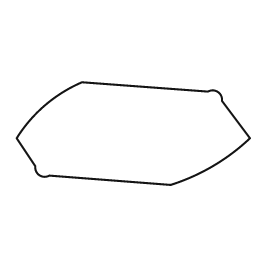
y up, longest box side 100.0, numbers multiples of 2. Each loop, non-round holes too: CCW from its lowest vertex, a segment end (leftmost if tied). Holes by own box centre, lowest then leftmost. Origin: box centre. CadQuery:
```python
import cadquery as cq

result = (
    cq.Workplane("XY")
    .moveTo(16.0, -22.0)
    .threePointArc((34.0, -14.0), (50.0, -2.0))
    .lineTo(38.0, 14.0)
    .threePointArc((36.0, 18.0), (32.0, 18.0))
    .lineTo(-22.0, 22.0)
    .threePointArc((-38.0, 12.0), (-50.0, -2.0))
    .lineTo(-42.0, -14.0)
    .threePointArc((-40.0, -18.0), (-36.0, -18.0))
    .close()
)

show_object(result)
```